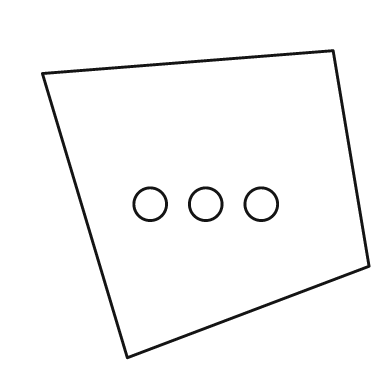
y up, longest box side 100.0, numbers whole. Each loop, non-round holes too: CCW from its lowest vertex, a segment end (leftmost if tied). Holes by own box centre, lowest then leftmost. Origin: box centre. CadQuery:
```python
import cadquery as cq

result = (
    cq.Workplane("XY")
    .moveTo(-24.0, -47.0)
    .lineTo(50.0, -19.0)
    .lineTo(39.0, 47.0)
    .lineTo(-50.0, 40.0)
    .close()
    .moveTo(-17.0, 0.0)
    .circle(5.0)
    .moveTo(0.0, 0.0)
    .circle(5.0)
    .moveTo(17.0, 0.0)
    .circle(5.0)
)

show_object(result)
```